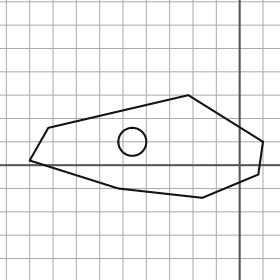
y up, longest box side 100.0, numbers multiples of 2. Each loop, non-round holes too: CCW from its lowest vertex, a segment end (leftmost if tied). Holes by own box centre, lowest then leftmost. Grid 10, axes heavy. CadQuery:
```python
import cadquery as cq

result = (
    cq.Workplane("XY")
    .moveTo(-16.0, -14.0)
    .lineTo(8.0, -4.0)
    .lineTo(10.0, 10.0)
    .lineTo(-22.0, 30.0)
    .lineTo(-82.0, 16.0)
    .lineTo(-90.0, 2.0)
    .lineTo(-52.0, -10.0)
    .close()
    .moveTo(-46.0, 10.0)
    .circle(6.0)
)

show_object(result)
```